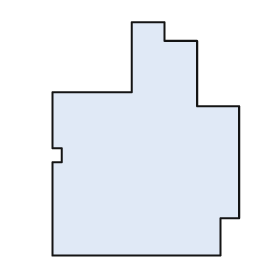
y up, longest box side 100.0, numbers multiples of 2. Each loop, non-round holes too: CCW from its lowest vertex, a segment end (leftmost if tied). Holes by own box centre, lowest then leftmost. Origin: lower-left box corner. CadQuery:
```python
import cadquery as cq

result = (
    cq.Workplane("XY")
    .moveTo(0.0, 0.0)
    .lineTo(72.0, 0.0)
    .lineTo(72.0, 16.0)
    .lineTo(80.0, 16.0)
    .lineTo(80.0, 64.0)
    .lineTo(62.0, 64.0)
    .lineTo(62.0, 92.0)
    .lineTo(48.0, 92.0)
    .lineTo(48.0, 100.0)
    .lineTo(34.0, 100.0)
    .lineTo(34.0, 70.0)
    .lineTo(0.0, 70.0)
    .lineTo(0.0, 46.0)
    .lineTo(4.0, 46.0)
    .lineTo(4.0, 40.0)
    .lineTo(0.0, 40.0)
    .close()
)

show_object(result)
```